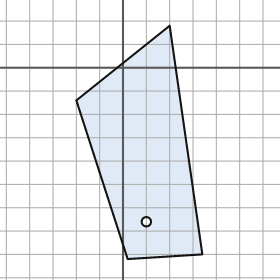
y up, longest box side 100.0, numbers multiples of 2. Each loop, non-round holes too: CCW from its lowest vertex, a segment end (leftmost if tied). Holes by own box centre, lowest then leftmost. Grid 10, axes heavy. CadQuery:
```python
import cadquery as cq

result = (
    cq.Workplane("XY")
    .moveTo(2.0, -82.0)
    .lineTo(34.0, -80.0)
    .lineTo(20.0, 18.0)
    .lineTo(-20.0, -14.0)
    .close()
    .moveTo(10.0, -66.0)
    .circle(2.0)
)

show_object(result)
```